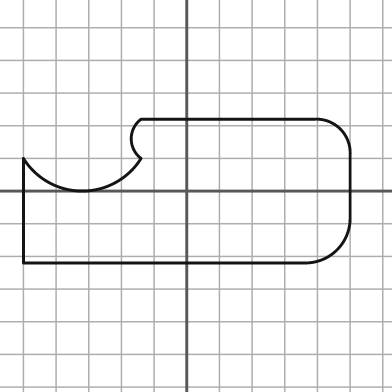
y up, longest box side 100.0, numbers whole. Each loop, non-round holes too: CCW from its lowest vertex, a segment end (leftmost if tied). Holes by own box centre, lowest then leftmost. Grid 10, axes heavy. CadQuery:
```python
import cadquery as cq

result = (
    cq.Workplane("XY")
    .moveTo(-50.0, -22.0)
    .lineTo(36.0, -22.0)
    .threePointArc((46.0, -18.0), (50.0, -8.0))
    .lineTo(50.0, 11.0)
    .threePointArc((47.0, 19.0), (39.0, 22.0))
    .lineTo(-14.0, 22.0)
    .threePointArc((-17.0, 16.0), (-14.0, 10.0))
    .threePointArc((-32.0, 0.0), (-50.0, 10.0))
    .close()
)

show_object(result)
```